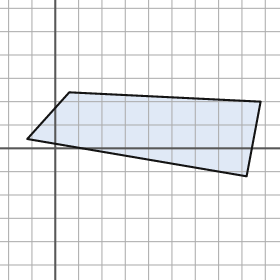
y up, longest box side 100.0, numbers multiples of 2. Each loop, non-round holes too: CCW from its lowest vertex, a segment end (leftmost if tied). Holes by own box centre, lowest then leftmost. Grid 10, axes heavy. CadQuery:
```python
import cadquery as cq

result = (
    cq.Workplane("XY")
    .moveTo(82.0, -12.0)
    .lineTo(88.0, 20.0)
    .lineTo(6.0, 24.0)
    .lineTo(-12.0, 4.0)
    .close()
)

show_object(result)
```